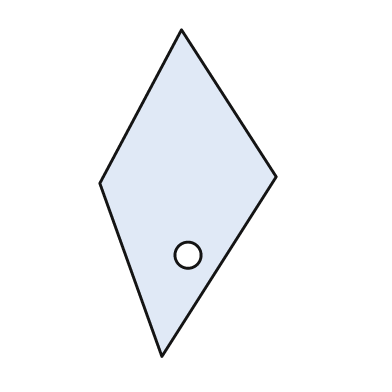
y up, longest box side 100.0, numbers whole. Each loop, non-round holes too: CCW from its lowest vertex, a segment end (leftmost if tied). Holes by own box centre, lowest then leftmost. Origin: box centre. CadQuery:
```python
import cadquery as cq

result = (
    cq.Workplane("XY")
    .moveTo(-8.0, -50.0)
    .lineTo(27.0, 5.0)
    .lineTo(-2.0, 50.0)
    .lineTo(-27.0, 3.0)
    .close()
    .moveTo(0.0, -19.0)
    .circle(4.0)
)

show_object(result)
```